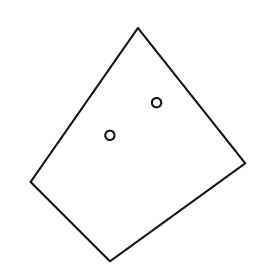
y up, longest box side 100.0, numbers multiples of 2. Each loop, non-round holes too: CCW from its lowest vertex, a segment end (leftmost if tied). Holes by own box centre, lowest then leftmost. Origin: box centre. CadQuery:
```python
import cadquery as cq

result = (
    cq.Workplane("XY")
    .moveTo(-12.0, -50.0)
    .lineTo(46.0, -8.0)
    .lineTo(0.0, 50.0)
    .lineTo(-46.0, -16.0)
    .close()
    .moveTo(-12.0, 4.0)
    .circle(2.0)
    .moveTo(8.0, 18.0)
    .circle(2.0)
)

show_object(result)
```